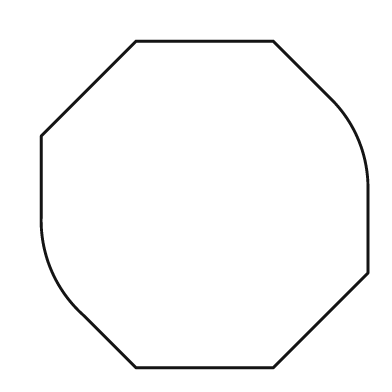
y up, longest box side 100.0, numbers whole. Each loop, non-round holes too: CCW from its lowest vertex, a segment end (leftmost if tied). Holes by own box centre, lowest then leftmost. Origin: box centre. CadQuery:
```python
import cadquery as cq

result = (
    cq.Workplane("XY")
    .moveTo(-21.0, -50.0)
    .lineTo(21.0, -50.0)
    .lineTo(50.0, -21.0)
    .lineTo(50.0, 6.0)
    .threePointArc((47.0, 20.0), (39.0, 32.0))
    .lineTo(21.0, 50.0)
    .lineTo(-21.0, 50.0)
    .lineTo(-50.0, 21.0)
    .lineTo(-50.0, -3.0)
    .threePointArc((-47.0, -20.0), (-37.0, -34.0))
    .close()
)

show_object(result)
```